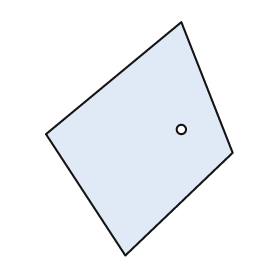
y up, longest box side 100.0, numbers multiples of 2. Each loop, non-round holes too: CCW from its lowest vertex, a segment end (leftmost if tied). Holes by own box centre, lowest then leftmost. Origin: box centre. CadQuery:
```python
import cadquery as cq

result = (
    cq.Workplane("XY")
    .moveTo(-6.0, -50.0)
    .lineTo(40.0, -6.0)
    .lineTo(18.0, 50.0)
    .lineTo(-40.0, 2.0)
    .close()
    .moveTo(18.0, 4.0)
    .circle(2.0)
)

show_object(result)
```